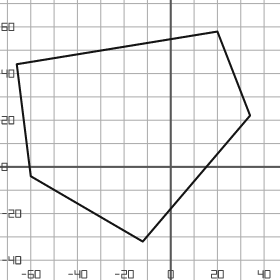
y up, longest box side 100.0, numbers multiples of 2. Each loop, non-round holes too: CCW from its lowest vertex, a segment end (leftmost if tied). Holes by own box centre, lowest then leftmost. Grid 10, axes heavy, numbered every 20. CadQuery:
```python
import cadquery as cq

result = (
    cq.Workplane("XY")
    .moveTo(-12.0, -32.0)
    .lineTo(34.0, 22.0)
    .lineTo(20.0, 58.0)
    .lineTo(-66.0, 44.0)
    .lineTo(-60.0, -4.0)
    .close()
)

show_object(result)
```